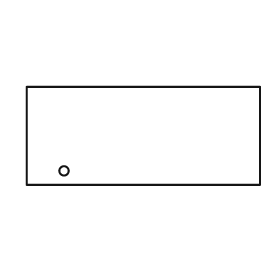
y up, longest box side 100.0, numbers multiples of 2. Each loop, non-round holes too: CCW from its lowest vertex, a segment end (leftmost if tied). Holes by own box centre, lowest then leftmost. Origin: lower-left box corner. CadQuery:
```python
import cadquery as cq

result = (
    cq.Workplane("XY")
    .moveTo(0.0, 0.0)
    .lineTo(100.0, 0.0)
    .lineTo(100.0, 42.0)
    .lineTo(0.0, 42.0)
    .close()
    .moveTo(16.0, 6.0)
    .circle(2.0)
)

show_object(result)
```